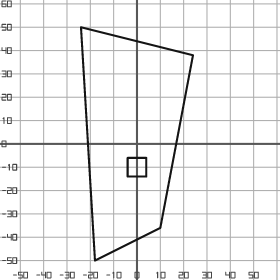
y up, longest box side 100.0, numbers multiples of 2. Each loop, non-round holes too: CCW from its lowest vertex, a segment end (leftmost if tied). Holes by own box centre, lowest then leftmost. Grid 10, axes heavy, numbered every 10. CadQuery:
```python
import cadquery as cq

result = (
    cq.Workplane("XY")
    .moveTo(-18.0, -50.0)
    .lineTo(10.0, -36.0)
    .lineTo(24.0, 38.0)
    .lineTo(-24.0, 50.0)
    .close()
    .moveTo(-4.0, -14.0)
    .lineTo(4.0, -14.0)
    .lineTo(4.0, -6.0)
    .lineTo(-4.0, -6.0)
    .close()
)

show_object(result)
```